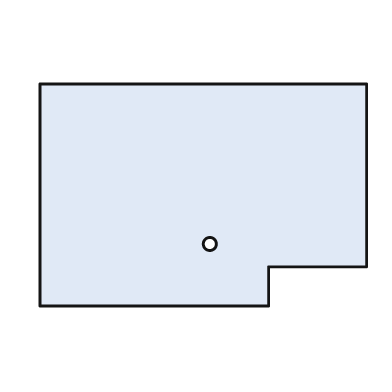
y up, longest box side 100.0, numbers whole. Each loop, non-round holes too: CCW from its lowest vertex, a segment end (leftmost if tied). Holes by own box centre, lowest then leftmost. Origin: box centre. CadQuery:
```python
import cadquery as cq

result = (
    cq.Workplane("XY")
    .moveTo(-50.0, -34.0)
    .lineTo(20.0, -34.0)
    .lineTo(20.0, -22.0)
    .lineTo(50.0, -22.0)
    .lineTo(50.0, 34.0)
    .lineTo(-50.0, 34.0)
    .close()
    .moveTo(2.0, -15.0)
    .circle(2.0)
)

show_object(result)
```